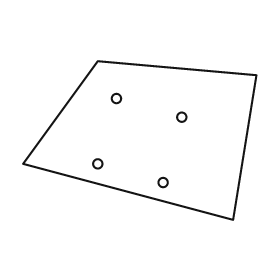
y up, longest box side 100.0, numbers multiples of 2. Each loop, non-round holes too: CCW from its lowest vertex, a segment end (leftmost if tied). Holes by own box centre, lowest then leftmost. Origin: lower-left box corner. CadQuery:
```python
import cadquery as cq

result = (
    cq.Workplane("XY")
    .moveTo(90.0, 0.0)
    .lineTo(100.0, 62.0)
    .lineTo(32.0, 68.0)
    .lineTo(0.0, 24.0)
    .close()
    .moveTo(60.0, 16.0)
    .circle(2.0)
    .moveTo(32.0, 24.0)
    .circle(2.0)
    .moveTo(68.0, 44.0)
    .circle(2.0)
    .moveTo(40.0, 52.0)
    .circle(2.0)
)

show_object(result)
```